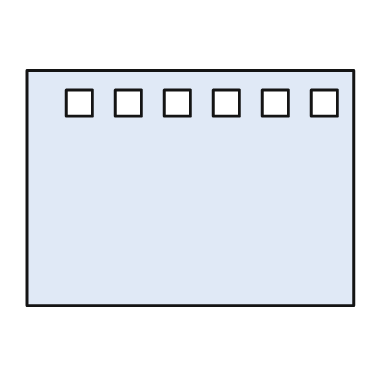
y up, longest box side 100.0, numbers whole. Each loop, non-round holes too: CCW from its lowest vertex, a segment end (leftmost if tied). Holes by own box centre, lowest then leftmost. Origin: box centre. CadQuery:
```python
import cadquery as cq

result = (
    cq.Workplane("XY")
    .moveTo(-50.0, -36.0)
    .lineTo(50.0, -36.0)
    .lineTo(50.0, 36.0)
    .lineTo(-50.0, 36.0)
    .close()
    .moveTo(-38.0, 22.0)
    .lineTo(-30.0, 22.0)
    .lineTo(-30.0, 30.0)
    .lineTo(-38.0, 30.0)
    .close()
    .moveTo(-23.0, 22.0)
    .lineTo(-15.0, 22.0)
    .lineTo(-15.0, 30.0)
    .lineTo(-23.0, 30.0)
    .close()
    .moveTo(-8.0, 22.0)
    .lineTo(0.0, 22.0)
    .lineTo(0.0, 30.0)
    .lineTo(-8.0, 30.0)
    .close()
    .moveTo(7.0, 22.0)
    .lineTo(15.0, 22.0)
    .lineTo(15.0, 30.0)
    .lineTo(7.0, 30.0)
    .close()
    .moveTo(22.0, 22.0)
    .lineTo(30.0, 22.0)
    .lineTo(30.0, 30.0)
    .lineTo(22.0, 30.0)
    .close()
    .moveTo(37.0, 22.0)
    .lineTo(45.0, 22.0)
    .lineTo(45.0, 30.0)
    .lineTo(37.0, 30.0)
    .close()
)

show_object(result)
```